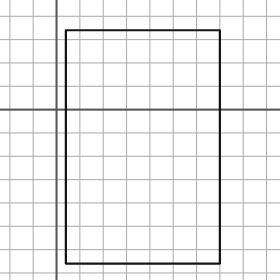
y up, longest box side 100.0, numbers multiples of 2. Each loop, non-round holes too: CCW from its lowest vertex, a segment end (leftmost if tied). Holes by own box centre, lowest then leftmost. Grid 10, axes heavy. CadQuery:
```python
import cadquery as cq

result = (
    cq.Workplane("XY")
    .moveTo(4.0, -66.0)
    .lineTo(70.0, -66.0)
    .lineTo(70.0, 34.0)
    .lineTo(4.0, 34.0)
    .close()
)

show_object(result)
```